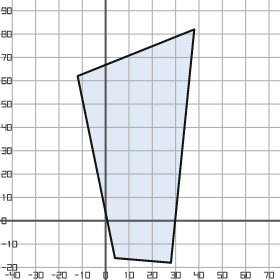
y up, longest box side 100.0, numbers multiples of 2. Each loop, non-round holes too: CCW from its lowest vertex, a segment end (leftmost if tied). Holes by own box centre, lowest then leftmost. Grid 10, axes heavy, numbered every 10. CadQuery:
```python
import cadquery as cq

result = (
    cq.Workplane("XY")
    .moveTo(28.0, -18.0)
    .lineTo(38.0, 82.0)
    .lineTo(-12.0, 62.0)
    .lineTo(4.0, -16.0)
    .close()
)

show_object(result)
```